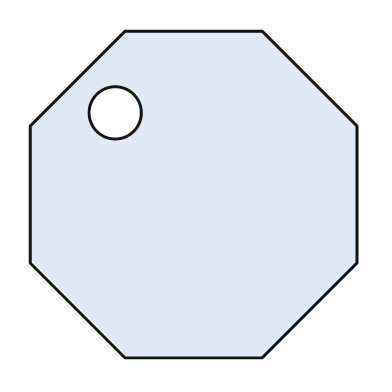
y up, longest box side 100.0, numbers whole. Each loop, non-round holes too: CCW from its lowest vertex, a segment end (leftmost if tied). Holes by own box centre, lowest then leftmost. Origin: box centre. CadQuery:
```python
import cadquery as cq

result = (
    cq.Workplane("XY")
    .moveTo(-21.0, -50.0)
    .lineTo(21.0, -50.0)
    .lineTo(50.0, -21.0)
    .lineTo(50.0, 21.0)
    .lineTo(21.0, 50.0)
    .lineTo(-21.0, 50.0)
    .lineTo(-50.0, 21.0)
    .lineTo(-50.0, -21.0)
    .close()
    .moveTo(-24.0, 25.0)
    .circle(8.0)
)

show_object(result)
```